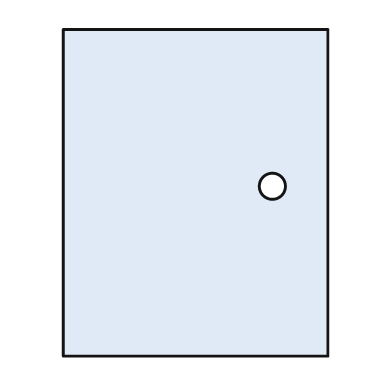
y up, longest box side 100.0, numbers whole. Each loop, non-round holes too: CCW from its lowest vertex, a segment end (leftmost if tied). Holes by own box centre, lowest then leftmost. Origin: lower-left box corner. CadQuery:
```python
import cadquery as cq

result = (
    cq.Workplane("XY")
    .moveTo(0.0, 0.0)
    .lineTo(81.0, 0.0)
    .lineTo(81.0, 100.0)
    .lineTo(0.0, 100.0)
    .close()
    .moveTo(64.0, 52.0)
    .circle(4.0)
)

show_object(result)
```